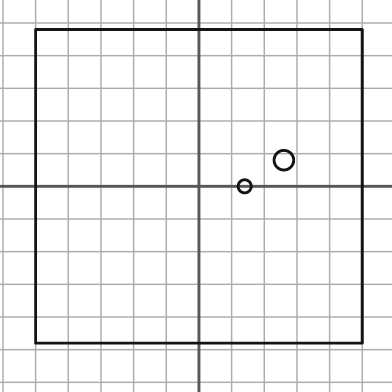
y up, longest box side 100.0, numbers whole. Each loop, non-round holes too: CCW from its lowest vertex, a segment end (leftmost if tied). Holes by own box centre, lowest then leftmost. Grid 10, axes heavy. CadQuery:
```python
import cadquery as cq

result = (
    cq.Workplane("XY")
    .moveTo(-50.0, -48.0)
    .lineTo(50.0, -48.0)
    .lineTo(50.0, 48.0)
    .lineTo(-50.0, 48.0)
    .close()
    .moveTo(14.0, 0.0)
    .circle(2.0)
    .moveTo(26.0, 8.0)
    .circle(3.0)
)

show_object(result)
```